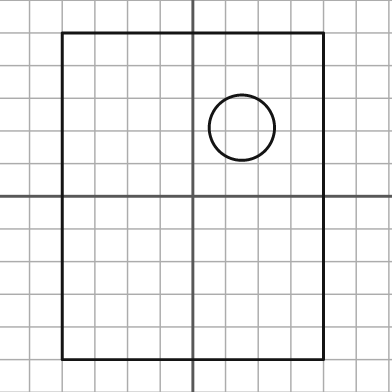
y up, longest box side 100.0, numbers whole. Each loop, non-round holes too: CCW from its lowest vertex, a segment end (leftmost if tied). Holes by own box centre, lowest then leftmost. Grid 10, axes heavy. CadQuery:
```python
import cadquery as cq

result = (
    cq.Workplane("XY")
    .moveTo(-40.0, -50.0)
    .lineTo(40.0, -50.0)
    .lineTo(40.0, 50.0)
    .lineTo(-40.0, 50.0)
    .close()
    .moveTo(15.0, 21.0)
    .circle(10.0)
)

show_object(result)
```